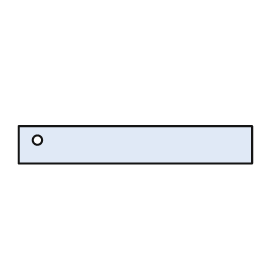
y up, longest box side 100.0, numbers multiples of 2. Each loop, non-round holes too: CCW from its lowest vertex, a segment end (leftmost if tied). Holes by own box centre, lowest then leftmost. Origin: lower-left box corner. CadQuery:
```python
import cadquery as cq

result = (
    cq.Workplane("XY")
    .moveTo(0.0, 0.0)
    .lineTo(100.0, 0.0)
    .lineTo(100.0, 16.0)
    .lineTo(0.0, 16.0)
    .close()
    .moveTo(8.0, 10.0)
    .circle(2.0)
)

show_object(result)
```